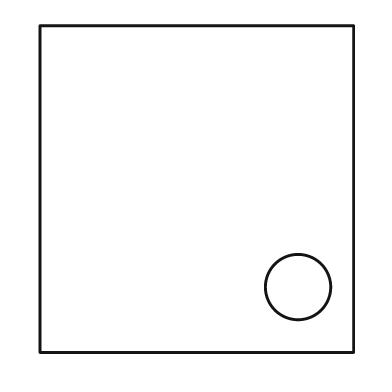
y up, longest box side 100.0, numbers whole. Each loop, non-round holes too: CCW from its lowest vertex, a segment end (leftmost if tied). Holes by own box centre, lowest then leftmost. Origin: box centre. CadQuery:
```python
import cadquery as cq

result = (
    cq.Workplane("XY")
    .moveTo(-48.0, -50.0)
    .lineTo(48.0, -50.0)
    .lineTo(48.0, 50.0)
    .lineTo(-48.0, 50.0)
    .close()
    .moveTo(31.0, -30.0)
    .circle(10.0)
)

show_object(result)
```